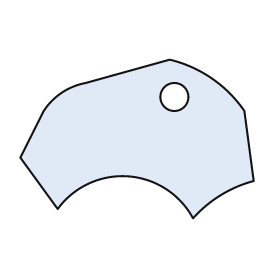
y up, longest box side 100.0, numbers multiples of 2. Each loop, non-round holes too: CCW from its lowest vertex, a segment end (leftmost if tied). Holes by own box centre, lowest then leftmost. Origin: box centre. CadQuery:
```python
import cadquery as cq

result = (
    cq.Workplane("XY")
    .moveTo(24.0, -34.0)
    .threePointArc((36.0, -24.0), (50.0, -18.0))
    .lineTo(46.0, 12.0)
    .threePointArc((32.0, 26.0), (14.0, 34.0))
    .lineTo(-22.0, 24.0)
    .threePointArc((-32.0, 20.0), (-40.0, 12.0))
    .lineTo(-50.0, -8.0)
    .lineTo(-34.0, -30.0)
    .threePointArc((-4.0, -16.0), (24.0, -34.0))
    .close()
    .moveTo(16.0, 18.0)
    .circle(6.0)
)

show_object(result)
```